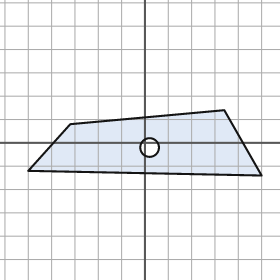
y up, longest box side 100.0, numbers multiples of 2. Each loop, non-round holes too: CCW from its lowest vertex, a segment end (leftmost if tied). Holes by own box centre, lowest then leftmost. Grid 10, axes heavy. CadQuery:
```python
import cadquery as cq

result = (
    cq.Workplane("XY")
    .moveTo(50.0, -14.0)
    .lineTo(34.0, 14.0)
    .lineTo(-32.0, 8.0)
    .lineTo(-50.0, -12.0)
    .close()
    .moveTo(2.0, -2.0)
    .circle(4.0)
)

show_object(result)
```